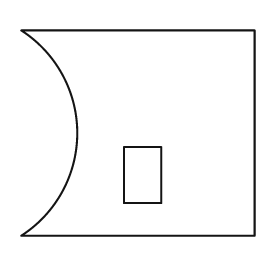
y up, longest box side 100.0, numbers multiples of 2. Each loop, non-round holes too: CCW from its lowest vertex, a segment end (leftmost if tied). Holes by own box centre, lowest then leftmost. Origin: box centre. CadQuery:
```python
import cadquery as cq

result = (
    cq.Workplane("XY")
    .moveTo(-50.0, -44.0)
    .lineTo(50.0, -44.0)
    .lineTo(50.0, 44.0)
    .lineTo(-50.0, 44.0)
    .threePointArc((-26.0, 0.0), (-50.0, -44.0))
    .close()
    .moveTo(-6.0, -30.0)
    .lineTo(10.0, -30.0)
    .lineTo(10.0, -6.0)
    .lineTo(-6.0, -6.0)
    .close()
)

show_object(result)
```